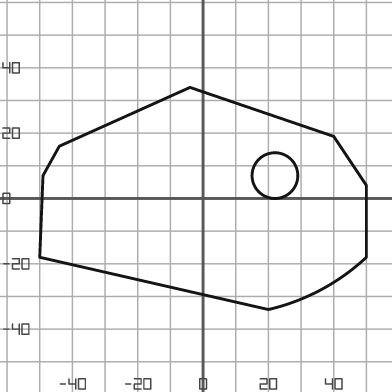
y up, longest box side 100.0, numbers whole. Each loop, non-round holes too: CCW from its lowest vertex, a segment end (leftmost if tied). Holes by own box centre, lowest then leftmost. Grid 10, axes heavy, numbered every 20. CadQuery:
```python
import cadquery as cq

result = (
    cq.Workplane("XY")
    .moveTo(20.0, -34.0)
    .threePointArc((36.0, -28.0), (50.0, -18.0))
    .lineTo(50.0, 4.0)
    .lineTo(40.0, 19.0)
    .lineTo(-4.0, 34.0)
    .lineTo(-44.0, 16.0)
    .lineTo(-49.0, 7.0)
    .lineTo(-50.0, -18.0)
    .close()
    .moveTo(22.0, 7.0)
    .circle(7.0)
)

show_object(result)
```